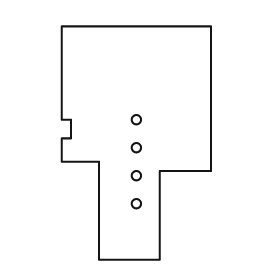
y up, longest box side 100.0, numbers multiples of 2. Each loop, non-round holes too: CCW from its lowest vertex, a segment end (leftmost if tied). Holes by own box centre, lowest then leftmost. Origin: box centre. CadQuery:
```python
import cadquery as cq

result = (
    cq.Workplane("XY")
    .moveTo(-16.0, -50.0)
    .lineTo(10.0, -50.0)
    .lineTo(10.0, -12.0)
    .lineTo(32.0, -12.0)
    .lineTo(32.0, 50.0)
    .lineTo(-32.0, 50.0)
    .lineTo(-32.0, 10.0)
    .lineTo(-28.0, 10.0)
    .lineTo(-28.0, 2.0)
    .lineTo(-32.0, 2.0)
    .lineTo(-32.0, -8.0)
    .lineTo(-16.0, -8.0)
    .close()
    .moveTo(0.0, -26.0)
    .circle(2.0)
    .moveTo(0.0, -14.0)
    .circle(2.0)
    .moveTo(0.0, -2.0)
    .circle(2.0)
    .moveTo(0.0, 10.0)
    .circle(2.0)
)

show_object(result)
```